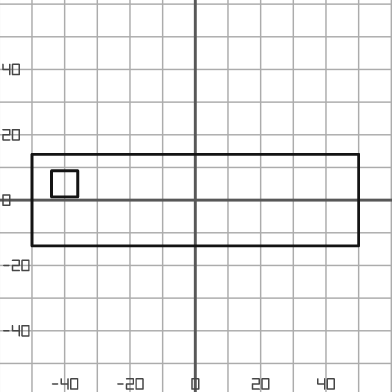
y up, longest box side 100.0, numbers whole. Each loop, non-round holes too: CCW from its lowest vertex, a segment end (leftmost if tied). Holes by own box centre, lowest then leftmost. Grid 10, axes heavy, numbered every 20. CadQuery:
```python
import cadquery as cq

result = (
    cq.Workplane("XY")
    .moveTo(-50.0, -14.0)
    .lineTo(50.0, -14.0)
    .lineTo(50.0, 14.0)
    .lineTo(-50.0, 14.0)
    .close()
    .moveTo(-44.0, 1.0)
    .lineTo(-36.0, 1.0)
    .lineTo(-36.0, 9.0)
    .lineTo(-44.0, 9.0)
    .close()
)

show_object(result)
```